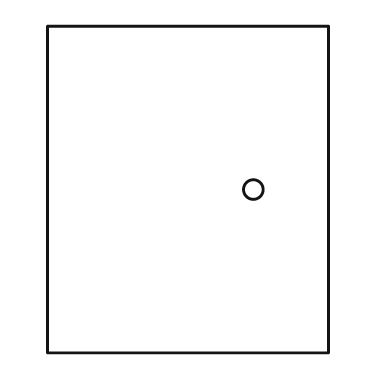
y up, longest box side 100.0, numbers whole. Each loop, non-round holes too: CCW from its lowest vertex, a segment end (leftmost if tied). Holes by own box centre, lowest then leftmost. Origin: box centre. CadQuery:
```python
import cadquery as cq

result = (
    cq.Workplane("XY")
    .moveTo(-43.0, -50.0)
    .lineTo(43.0, -50.0)
    .lineTo(43.0, 50.0)
    .lineTo(-43.0, 50.0)
    .close()
    .moveTo(20.0, 0.0)
    .circle(3.0)
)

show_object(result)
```